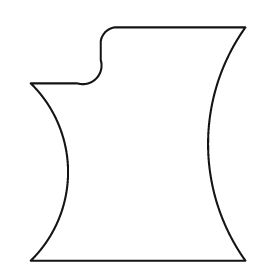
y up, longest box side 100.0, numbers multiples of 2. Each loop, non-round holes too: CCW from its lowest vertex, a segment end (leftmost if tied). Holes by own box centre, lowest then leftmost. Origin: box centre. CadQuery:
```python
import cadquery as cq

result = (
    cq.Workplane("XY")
    .moveTo(-46.0, -50.0)
    .lineTo(46.0, -50.0)
    .threePointArc((30.0, 0.0), (46.0, 50.0))
    .lineTo(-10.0, 50.0)
    .threePointArc((-14.0, 48.0), (-16.0, 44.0))
    .lineTo(-16.0, 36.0)
    .threePointArc((-18.0, 28.0), (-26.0, 26.0))
    .lineTo(-46.0, 26.0)
    .threePointArc((-30.0, -12.0), (-46.0, -50.0))
    .close()
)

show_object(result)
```